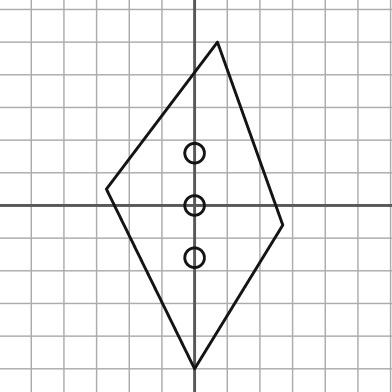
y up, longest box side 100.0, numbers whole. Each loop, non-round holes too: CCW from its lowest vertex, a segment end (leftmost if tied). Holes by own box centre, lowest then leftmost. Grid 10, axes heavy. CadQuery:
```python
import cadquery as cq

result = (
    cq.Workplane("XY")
    .moveTo(0.0, -50.0)
    .lineTo(27.0, -6.0)
    .lineTo(7.0, 50.0)
    .lineTo(-27.0, 5.0)
    .close()
    .moveTo(0.0, -16.0)
    .circle(3.0)
    .moveTo(0.0, 0.0)
    .circle(3.0)
    .moveTo(0.0, 16.0)
    .circle(3.0)
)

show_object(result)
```